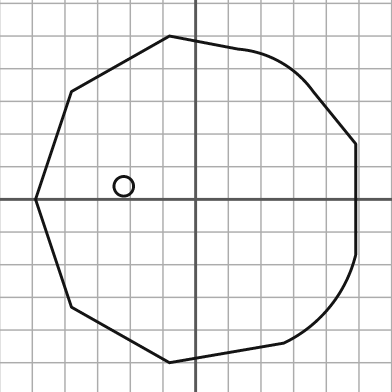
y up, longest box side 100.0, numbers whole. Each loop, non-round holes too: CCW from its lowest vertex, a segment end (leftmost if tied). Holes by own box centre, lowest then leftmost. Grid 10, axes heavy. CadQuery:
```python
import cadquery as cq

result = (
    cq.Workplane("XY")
    .moveTo(-8.0, -50.0)
    .lineTo(27.0, -44.0)
    .threePointArc((41.0, -33.0), (49.0, -17.0))
    .lineTo(49.0, 17.0)
    .lineTo(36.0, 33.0)
    .threePointArc((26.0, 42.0), (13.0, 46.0))
    .lineTo(-8.0, 50.0)
    .lineTo(-38.0, 33.0)
    .lineTo(-49.0, 0.0)
    .lineTo(-38.0, -33.0)
    .close()
    .moveTo(-22.0, 4.0)
    .circle(3.0)
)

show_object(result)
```